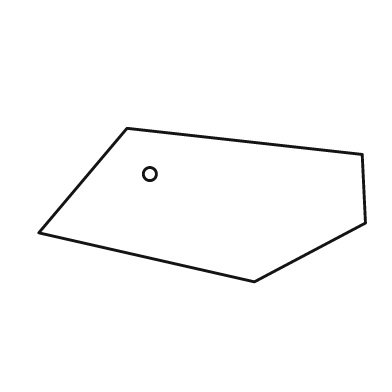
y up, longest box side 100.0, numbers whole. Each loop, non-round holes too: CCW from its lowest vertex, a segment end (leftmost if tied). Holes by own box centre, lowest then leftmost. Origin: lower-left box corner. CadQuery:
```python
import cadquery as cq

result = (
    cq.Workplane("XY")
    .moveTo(66.0, 0.0)
    .lineTo(100.0, 18.0)
    .lineTo(99.0, 39.0)
    .lineTo(27.0, 47.0)
    .lineTo(0.0, 15.0)
    .close()
    .moveTo(34.0, 33.0)
    .circle(2.0)
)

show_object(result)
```